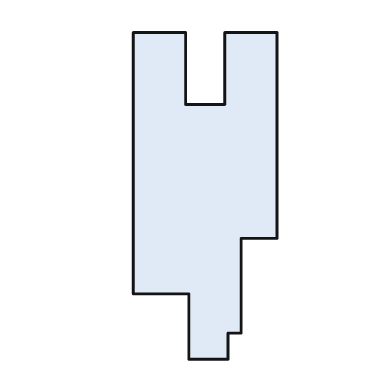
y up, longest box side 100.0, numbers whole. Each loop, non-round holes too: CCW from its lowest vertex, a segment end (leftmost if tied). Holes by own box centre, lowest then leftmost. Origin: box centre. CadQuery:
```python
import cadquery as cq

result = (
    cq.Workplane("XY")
    .moveTo(-5.0, -50.0)
    .lineTo(7.0, -50.0)
    .lineTo(7.0, -42.0)
    .lineTo(11.0, -42.0)
    .lineTo(11.0, -13.0)
    .lineTo(22.0, -13.0)
    .lineTo(22.0, 50.0)
    .lineTo(6.0, 50.0)
    .lineTo(6.0, 28.0)
    .lineTo(-6.0, 28.0)
    .lineTo(-6.0, 50.0)
    .lineTo(-22.0, 50.0)
    .lineTo(-22.0, -30.0)
    .lineTo(-5.0, -30.0)
    .close()
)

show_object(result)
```